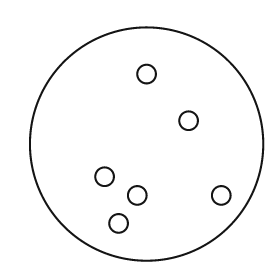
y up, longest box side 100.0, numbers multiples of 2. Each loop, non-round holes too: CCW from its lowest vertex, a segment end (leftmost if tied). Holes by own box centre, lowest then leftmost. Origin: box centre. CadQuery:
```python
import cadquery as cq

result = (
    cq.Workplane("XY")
    .moveTo(0.0, 0.0)
    .circle(50.0)
    .moveTo(-12.0, -34.0)
    .circle(4.0)
    .moveTo(-4.0, -22.0)
    .circle(4.0)
    .moveTo(32.0, -22.0)
    .circle(4.0)
    .moveTo(-18.0, -14.0)
    .circle(4.0)
    .moveTo(18.0, 10.0)
    .circle(4.0)
    .moveTo(0.0, 30.0)
    .circle(4.0)
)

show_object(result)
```